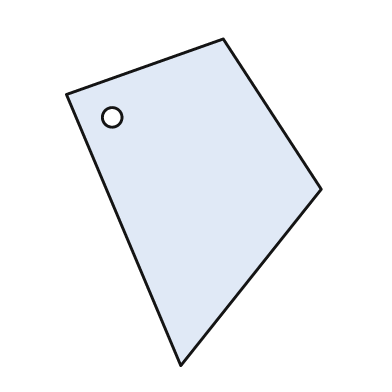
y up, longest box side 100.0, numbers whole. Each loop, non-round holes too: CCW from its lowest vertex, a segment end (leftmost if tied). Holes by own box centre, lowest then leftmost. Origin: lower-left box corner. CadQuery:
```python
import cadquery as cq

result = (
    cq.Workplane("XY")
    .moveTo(35.0, 0.0)
    .lineTo(78.0, 54.0)
    .lineTo(48.0, 100.0)
    .lineTo(0.0, 83.0)
    .close()
    .moveTo(14.0, 76.0)
    .circle(3.0)
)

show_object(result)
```